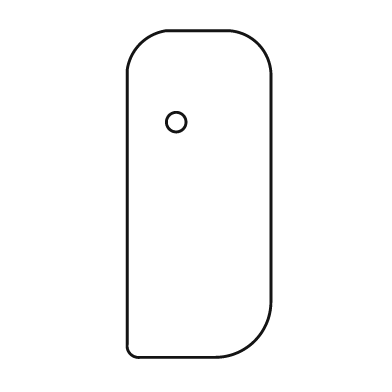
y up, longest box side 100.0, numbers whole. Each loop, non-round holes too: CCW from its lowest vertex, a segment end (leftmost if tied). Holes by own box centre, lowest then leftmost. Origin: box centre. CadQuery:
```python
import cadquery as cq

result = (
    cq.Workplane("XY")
    .moveTo(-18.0, -50.0)
    .lineTo(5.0, -50.0)
    .threePointArc((17.0, -45.0), (22.0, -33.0))
    .lineTo(22.0, 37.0)
    .threePointArc((18.0, 46.0), (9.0, 50.0))
    .lineTo(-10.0, 50.0)
    .threePointArc((-18.0, 46.0), (-22.0, 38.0))
    .lineTo(-22.0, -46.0)
    .threePointArc((-21.0, -49.0), (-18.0, -50.0))
    .close()
    .moveTo(-7.0, 22.0)
    .circle(3.0)
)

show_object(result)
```